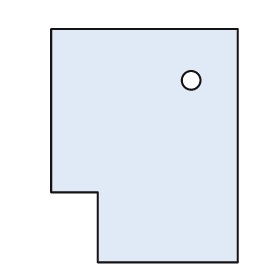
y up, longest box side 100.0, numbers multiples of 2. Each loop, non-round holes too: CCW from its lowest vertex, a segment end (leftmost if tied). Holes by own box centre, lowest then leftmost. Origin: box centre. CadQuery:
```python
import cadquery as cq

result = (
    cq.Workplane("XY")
    .moveTo(-20.0, -50.0)
    .lineTo(40.0, -50.0)
    .lineTo(40.0, 50.0)
    .lineTo(-40.0, 50.0)
    .lineTo(-40.0, -20.0)
    .lineTo(-20.0, -20.0)
    .close()
    .moveTo(20.0, 28.0)
    .circle(4.0)
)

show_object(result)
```